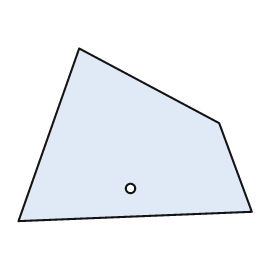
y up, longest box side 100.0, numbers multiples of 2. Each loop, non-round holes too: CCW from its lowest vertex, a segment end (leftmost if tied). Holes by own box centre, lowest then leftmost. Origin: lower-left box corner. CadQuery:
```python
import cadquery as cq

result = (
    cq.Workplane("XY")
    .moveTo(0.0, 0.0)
    .lineTo(100.0, 4.0)
    .lineTo(86.0, 42.0)
    .lineTo(26.0, 74.0)
    .close()
    .moveTo(48.0, 14.0)
    .circle(2.0)
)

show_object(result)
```